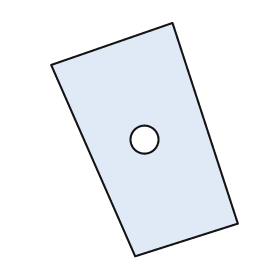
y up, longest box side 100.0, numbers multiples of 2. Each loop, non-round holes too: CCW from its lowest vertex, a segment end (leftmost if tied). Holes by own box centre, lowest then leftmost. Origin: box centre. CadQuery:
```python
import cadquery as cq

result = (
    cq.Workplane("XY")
    .moveTo(-4.0, -50.0)
    .lineTo(40.0, -36.0)
    .lineTo(12.0, 50.0)
    .lineTo(-40.0, 32.0)
    .close()
    .moveTo(0.0, 0.0)
    .circle(6.0)
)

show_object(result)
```